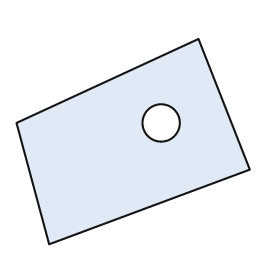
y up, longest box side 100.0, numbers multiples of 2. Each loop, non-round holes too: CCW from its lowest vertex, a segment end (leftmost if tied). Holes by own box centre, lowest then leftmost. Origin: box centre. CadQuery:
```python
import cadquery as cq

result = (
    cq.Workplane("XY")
    .moveTo(-36.0, -44.0)
    .lineTo(50.0, -12.0)
    .lineTo(28.0, 44.0)
    .lineTo(-50.0, 8.0)
    .close()
    .moveTo(12.0, 8.0)
    .circle(8.0)
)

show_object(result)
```